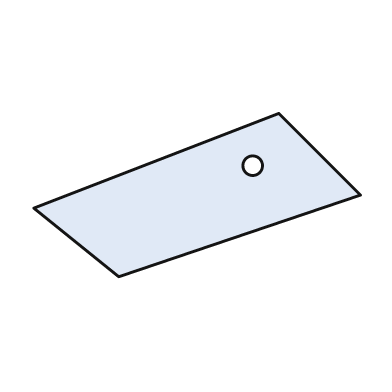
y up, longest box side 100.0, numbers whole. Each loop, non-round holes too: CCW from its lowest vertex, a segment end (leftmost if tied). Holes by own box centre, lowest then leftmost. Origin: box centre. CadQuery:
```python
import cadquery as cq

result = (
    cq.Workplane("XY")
    .moveTo(-24.0, -25.0)
    .lineTo(50.0, 0.0)
    .lineTo(25.0, 25.0)
    .lineTo(-50.0, -4.0)
    .close()
    .moveTo(17.0, 9.0)
    .circle(3.0)
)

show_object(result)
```